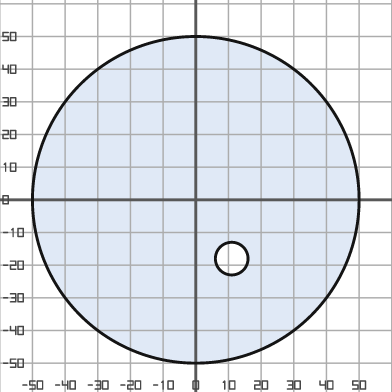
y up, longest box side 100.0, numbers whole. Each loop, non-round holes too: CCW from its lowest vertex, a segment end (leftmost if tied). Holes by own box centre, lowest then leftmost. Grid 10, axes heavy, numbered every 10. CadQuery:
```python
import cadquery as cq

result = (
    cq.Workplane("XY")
    .moveTo(0.0, 0.0)
    .circle(50.0)
    .moveTo(11.0, -18.0)
    .circle(5.0)
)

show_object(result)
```